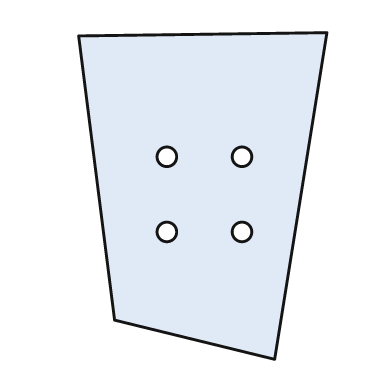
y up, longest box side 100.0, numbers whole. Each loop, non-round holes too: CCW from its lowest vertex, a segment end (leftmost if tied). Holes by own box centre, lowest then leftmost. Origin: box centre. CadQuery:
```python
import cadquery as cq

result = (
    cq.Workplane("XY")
    .moveTo(22.0, -50.0)
    .lineTo(38.0, 50.0)
    .lineTo(-38.0, 49.0)
    .lineTo(-27.0, -38.0)
    .close()
    .moveTo(-11.0, -11.0)
    .circle(3.0)
    .moveTo(12.0, -11.0)
    .circle(3.0)
    .moveTo(-11.0, 12.0)
    .circle(3.0)
    .moveTo(12.0, 12.0)
    .circle(3.0)
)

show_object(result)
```